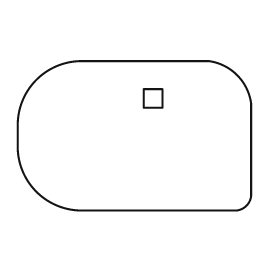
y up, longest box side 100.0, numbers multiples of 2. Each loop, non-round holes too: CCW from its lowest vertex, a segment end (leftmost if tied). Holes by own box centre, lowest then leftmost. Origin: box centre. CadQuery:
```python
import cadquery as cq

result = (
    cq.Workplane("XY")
    .moveTo(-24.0, -32.0)
    .lineTo(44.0, -32.0)
    .threePointArc((48.0, -30.0), (50.0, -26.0))
    .lineTo(50.0, 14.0)
    .threePointArc((44.0, 26.0), (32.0, 32.0))
    .lineTo(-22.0, 32.0)
    .threePointArc((-42.0, 24.0), (-50.0, 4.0))
    .lineTo(-50.0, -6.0)
    .threePointArc((-42.0, -24.0), (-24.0, -32.0))
    .close()
    .moveTo(4.0, 12.0)
    .lineTo(12.0, 12.0)
    .lineTo(12.0, 20.0)
    .lineTo(4.0, 20.0)
    .close()
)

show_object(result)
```